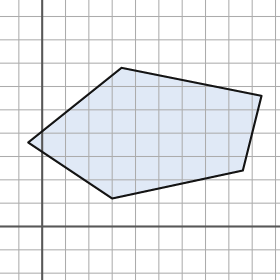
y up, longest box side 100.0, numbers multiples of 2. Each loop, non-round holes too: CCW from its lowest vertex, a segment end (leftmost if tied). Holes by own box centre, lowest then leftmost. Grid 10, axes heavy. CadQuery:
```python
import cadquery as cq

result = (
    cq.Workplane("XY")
    .moveTo(30.0, 12.0)
    .lineTo(86.0, 24.0)
    .lineTo(94.0, 56.0)
    .lineTo(34.0, 68.0)
    .lineTo(-6.0, 36.0)
    .close()
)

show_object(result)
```